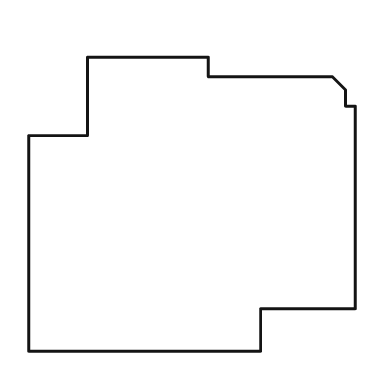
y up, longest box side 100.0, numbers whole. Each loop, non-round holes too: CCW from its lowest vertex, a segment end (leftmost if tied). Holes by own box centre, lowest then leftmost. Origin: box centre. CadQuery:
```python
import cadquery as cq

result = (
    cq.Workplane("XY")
    .moveTo(-50.0, -45.0)
    .lineTo(21.0, -45.0)
    .lineTo(21.0, -32.0)
    .lineTo(50.0, -32.0)
    .lineTo(50.0, 30.0)
    .lineTo(47.0, 30.0)
    .lineTo(47.0, 35.0)
    .lineTo(43.0, 39.0)
    .lineTo(5.0, 39.0)
    .lineTo(5.0, 45.0)
    .lineTo(-32.0, 45.0)
    .lineTo(-32.0, 21.0)
    .lineTo(-50.0, 21.0)
    .close()
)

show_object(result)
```